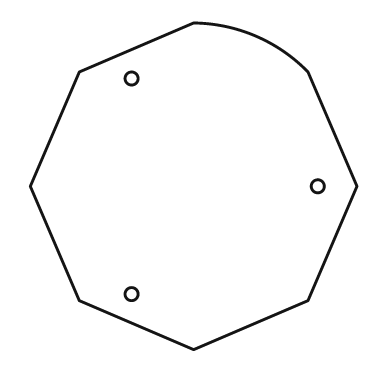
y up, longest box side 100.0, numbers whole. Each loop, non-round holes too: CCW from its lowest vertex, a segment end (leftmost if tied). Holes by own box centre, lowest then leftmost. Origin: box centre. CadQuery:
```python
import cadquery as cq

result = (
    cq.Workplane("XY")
    .moveTo(0.0, -50.0)
    .lineTo(35.0, -35.0)
    .lineTo(50.0, 0.0)
    .lineTo(35.0, 35.0)
    .threePointArc((19.0, 46.0), (0.0, 50.0))
    .lineTo(-35.0, 35.0)
    .lineTo(-50.0, 0.0)
    .lineTo(-35.0, -35.0)
    .close()
    .moveTo(-19.0, -33.0)
    .circle(2.0)
    .moveTo(38.0, 0.0)
    .circle(2.0)
    .moveTo(-19.0, 33.0)
    .circle(2.0)
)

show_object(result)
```